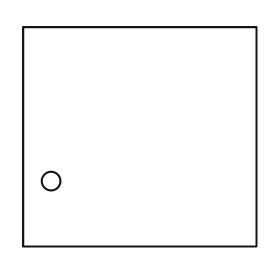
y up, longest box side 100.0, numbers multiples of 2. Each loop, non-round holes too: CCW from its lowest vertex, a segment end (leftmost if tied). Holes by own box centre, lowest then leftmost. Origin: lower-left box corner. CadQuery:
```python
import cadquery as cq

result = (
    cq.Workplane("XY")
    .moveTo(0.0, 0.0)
    .lineTo(100.0, 0.0)
    .lineTo(100.0, 94.0)
    .lineTo(0.0, 94.0)
    .close()
    .moveTo(12.0, 28.0)
    .circle(4.0)
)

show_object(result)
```